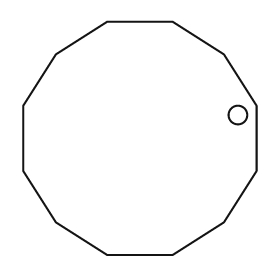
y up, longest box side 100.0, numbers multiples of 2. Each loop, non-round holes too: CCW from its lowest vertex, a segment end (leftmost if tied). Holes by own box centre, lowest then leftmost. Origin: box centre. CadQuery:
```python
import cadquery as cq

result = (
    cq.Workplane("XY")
    .moveTo(-14.0, -50.0)
    .lineTo(14.0, -50.0)
    .lineTo(36.0, -36.0)
    .lineTo(50.0, -14.0)
    .lineTo(50.0, 14.0)
    .lineTo(36.0, 36.0)
    .lineTo(14.0, 50.0)
    .lineTo(-14.0, 50.0)
    .lineTo(-36.0, 36.0)
    .lineTo(-50.0, 14.0)
    .lineTo(-50.0, -14.0)
    .lineTo(-36.0, -36.0)
    .close()
    .moveTo(42.0, 10.0)
    .circle(4.0)
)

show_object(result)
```